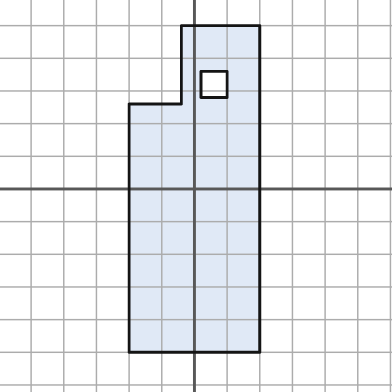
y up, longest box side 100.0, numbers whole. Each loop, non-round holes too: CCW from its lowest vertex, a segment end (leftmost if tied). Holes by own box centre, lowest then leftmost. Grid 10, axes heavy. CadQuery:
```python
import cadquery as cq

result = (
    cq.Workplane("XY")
    .moveTo(-20.0, -50.0)
    .lineTo(20.0, -50.0)
    .lineTo(20.0, 50.0)
    .lineTo(-4.0, 50.0)
    .lineTo(-4.0, 26.0)
    .lineTo(-20.0, 26.0)
    .close()
    .moveTo(2.0, 28.0)
    .lineTo(10.0, 28.0)
    .lineTo(10.0, 36.0)
    .lineTo(2.0, 36.0)
    .close()
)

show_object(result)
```